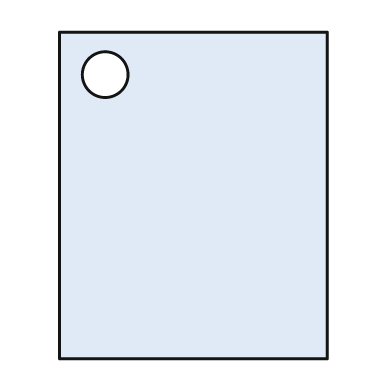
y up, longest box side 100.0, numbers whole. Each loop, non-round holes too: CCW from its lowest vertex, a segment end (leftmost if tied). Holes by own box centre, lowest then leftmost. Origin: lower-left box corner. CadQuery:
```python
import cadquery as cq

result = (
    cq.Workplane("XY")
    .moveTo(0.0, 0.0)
    .lineTo(82.0, 0.0)
    .lineTo(82.0, 100.0)
    .lineTo(0.0, 100.0)
    .close()
    .moveTo(14.0, 87.0)
    .circle(7.0)
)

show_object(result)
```